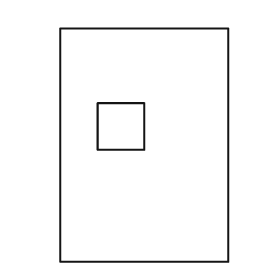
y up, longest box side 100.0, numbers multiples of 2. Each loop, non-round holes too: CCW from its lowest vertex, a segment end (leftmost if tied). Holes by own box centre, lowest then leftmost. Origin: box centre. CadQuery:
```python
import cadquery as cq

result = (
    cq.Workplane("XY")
    .moveTo(-36.0, -50.0)
    .lineTo(36.0, -50.0)
    .lineTo(36.0, 50.0)
    .lineTo(-36.0, 50.0)
    .close()
    .moveTo(-20.0, -2.0)
    .lineTo(0.0, -2.0)
    .lineTo(0.0, 18.0)
    .lineTo(-20.0, 18.0)
    .close()
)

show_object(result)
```